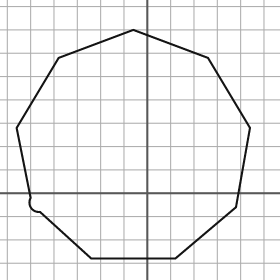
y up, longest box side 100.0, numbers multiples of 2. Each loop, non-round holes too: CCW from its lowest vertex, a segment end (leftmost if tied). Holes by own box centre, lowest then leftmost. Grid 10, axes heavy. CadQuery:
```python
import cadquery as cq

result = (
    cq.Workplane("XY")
    .moveTo(-24.0, -28.0)
    .lineTo(12.0, -28.0)
    .lineTo(38.0, -6.0)
    .lineTo(44.0, 28.0)
    .lineTo(26.0, 58.0)
    .lineTo(-6.0, 70.0)
    .lineTo(-38.0, 58.0)
    .lineTo(-56.0, 28.0)
    .lineTo(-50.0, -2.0)
    .threePointArc((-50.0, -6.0), (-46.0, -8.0))
    .close()
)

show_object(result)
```